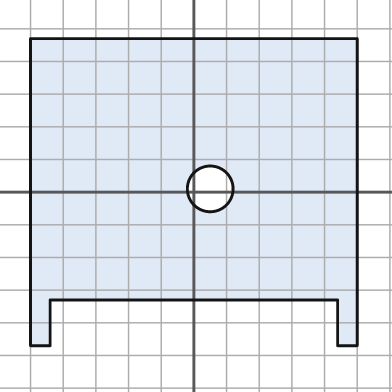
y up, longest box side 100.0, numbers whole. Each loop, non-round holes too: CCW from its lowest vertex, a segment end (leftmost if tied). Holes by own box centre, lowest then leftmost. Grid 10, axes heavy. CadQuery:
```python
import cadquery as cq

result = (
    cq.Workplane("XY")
    .moveTo(-50.0, -47.0)
    .lineTo(-44.0, -47.0)
    .lineTo(-44.0, -33.0)
    .lineTo(44.0, -33.0)
    .lineTo(44.0, -47.0)
    .lineTo(50.0, -47.0)
    .lineTo(50.0, 47.0)
    .lineTo(-50.0, 47.0)
    .close()
    .moveTo(5.0, 1.0)
    .circle(7.0)
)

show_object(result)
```